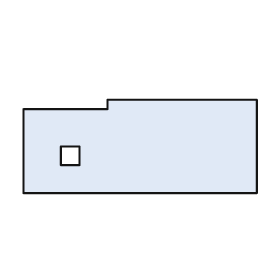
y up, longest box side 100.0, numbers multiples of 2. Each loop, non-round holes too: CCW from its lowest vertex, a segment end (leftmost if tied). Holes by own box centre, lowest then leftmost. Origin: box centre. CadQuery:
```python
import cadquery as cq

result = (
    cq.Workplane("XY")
    .moveTo(-50.0, -20.0)
    .lineTo(50.0, -20.0)
    .lineTo(50.0, 20.0)
    .lineTo(-14.0, 20.0)
    .lineTo(-14.0, 16.0)
    .lineTo(-50.0, 16.0)
    .close()
    .moveTo(-34.0, -8.0)
    .lineTo(-26.0, -8.0)
    .lineTo(-26.0, 0.0)
    .lineTo(-34.0, 0.0)
    .close()
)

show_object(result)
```